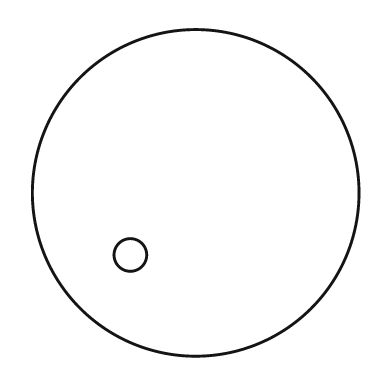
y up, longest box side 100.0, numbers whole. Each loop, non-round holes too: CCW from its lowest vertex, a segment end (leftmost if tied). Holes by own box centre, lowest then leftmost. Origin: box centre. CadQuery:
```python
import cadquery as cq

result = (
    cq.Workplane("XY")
    .moveTo(0.0, 0.0)
    .circle(50.0)
    .moveTo(-20.0, -19.0)
    .circle(5.0)
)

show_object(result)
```